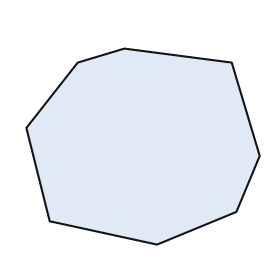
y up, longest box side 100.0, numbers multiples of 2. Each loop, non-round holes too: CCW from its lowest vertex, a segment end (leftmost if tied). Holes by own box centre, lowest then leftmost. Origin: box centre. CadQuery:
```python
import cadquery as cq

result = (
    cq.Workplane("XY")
    .moveTo(6.0, -42.0)
    .lineTo(40.0, -28.0)
    .lineTo(50.0, -4.0)
    .lineTo(38.0, 36.0)
    .lineTo(-8.0, 42.0)
    .lineTo(-28.0, 36.0)
    .lineTo(-50.0, 8.0)
    .lineTo(-40.0, -32.0)
    .close()
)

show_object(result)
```